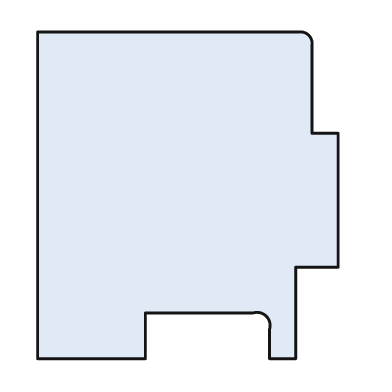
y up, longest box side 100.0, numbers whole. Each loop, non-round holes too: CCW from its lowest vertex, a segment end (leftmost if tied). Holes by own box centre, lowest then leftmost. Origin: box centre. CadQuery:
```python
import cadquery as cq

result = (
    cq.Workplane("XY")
    .moveTo(-46.0, -50.0)
    .lineTo(-13.0, -50.0)
    .lineTo(-13.0, -36.0)
    .lineTo(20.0, -36.0)
    .threePointArc((24.0, -37.0), (25.0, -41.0))
    .lineTo(25.0, -50.0)
    .lineTo(33.0, -50.0)
    .lineTo(33.0, -22.0)
    .lineTo(46.0, -22.0)
    .lineTo(46.0, 19.0)
    .lineTo(38.0, 19.0)
    .lineTo(38.0, 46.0)
    .threePointArc((37.0, 49.0), (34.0, 50.0))
    .lineTo(-46.0, 50.0)
    .close()
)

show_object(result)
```